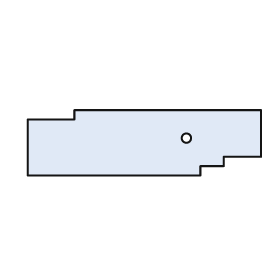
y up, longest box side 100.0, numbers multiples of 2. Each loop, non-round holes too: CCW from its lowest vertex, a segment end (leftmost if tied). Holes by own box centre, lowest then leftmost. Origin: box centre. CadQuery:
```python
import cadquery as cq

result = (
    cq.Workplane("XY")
    .moveTo(-50.0, -14.0)
    .lineTo(24.0, -14.0)
    .lineTo(24.0, -10.0)
    .lineTo(34.0, -10.0)
    .lineTo(34.0, -6.0)
    .lineTo(50.0, -6.0)
    .lineTo(50.0, 14.0)
    .lineTo(-30.0, 14.0)
    .lineTo(-30.0, 10.0)
    .lineTo(-50.0, 10.0)
    .close()
    .moveTo(18.0, 2.0)
    .circle(2.0)
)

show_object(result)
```